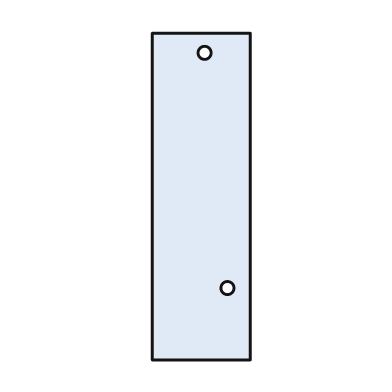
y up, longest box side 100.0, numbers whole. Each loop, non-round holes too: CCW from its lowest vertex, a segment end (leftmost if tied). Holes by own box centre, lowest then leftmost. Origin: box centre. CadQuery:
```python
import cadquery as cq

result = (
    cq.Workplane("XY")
    .moveTo(-15.0, -50.0)
    .lineTo(15.0, -50.0)
    .lineTo(15.0, 50.0)
    .lineTo(-15.0, 50.0)
    .close()
    .moveTo(8.0, -28.0)
    .circle(2.0)
    .moveTo(1.0, 44.0)
    .circle(2.0)
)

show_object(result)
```